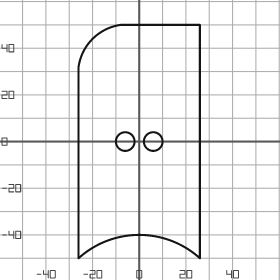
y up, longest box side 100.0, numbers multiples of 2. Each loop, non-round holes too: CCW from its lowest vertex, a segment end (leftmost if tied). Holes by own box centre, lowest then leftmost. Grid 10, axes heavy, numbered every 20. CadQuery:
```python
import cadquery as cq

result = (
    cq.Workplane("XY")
    .moveTo(-26.0, -50.0)
    .threePointArc((0.0, -40.0), (26.0, -50.0))
    .lineTo(26.0, 50.0)
    .lineTo(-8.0, 50.0)
    .threePointArc((-20.0, 44.0), (-26.0, 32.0))
    .close()
    .moveTo(-6.0, 0.0)
    .circle(4.0)
    .moveTo(6.0, 0.0)
    .circle(4.0)
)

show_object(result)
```